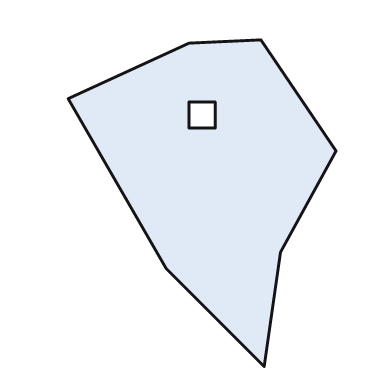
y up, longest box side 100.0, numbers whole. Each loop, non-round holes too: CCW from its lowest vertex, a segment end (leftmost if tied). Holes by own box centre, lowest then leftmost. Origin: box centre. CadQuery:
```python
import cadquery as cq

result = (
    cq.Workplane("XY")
    .moveTo(19.0, -50.0)
    .lineTo(24.0, -15.0)
    .lineTo(41.0, 16.0)
    .lineTo(18.0, 50.0)
    .lineTo(-4.0, 49.0)
    .lineTo(-41.0, 32.0)
    .lineTo(-11.0, -20.0)
    .close()
    .moveTo(-4.0, 23.0)
    .lineTo(4.0, 23.0)
    .lineTo(4.0, 31.0)
    .lineTo(-4.0, 31.0)
    .close()
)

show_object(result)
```